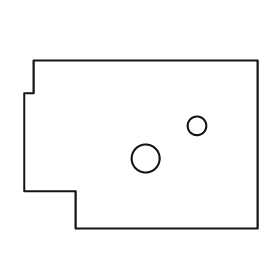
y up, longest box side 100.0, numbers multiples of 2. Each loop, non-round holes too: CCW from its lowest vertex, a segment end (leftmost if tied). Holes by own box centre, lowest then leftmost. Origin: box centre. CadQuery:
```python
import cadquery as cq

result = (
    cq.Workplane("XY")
    .moveTo(-28.0, -36.0)
    .lineTo(50.0, -36.0)
    .lineTo(50.0, 36.0)
    .lineTo(-46.0, 36.0)
    .lineTo(-46.0, 22.0)
    .lineTo(-50.0, 22.0)
    .lineTo(-50.0, -20.0)
    .lineTo(-28.0, -20.0)
    .close()
    .moveTo(2.0, -6.0)
    .circle(6.0)
    .moveTo(24.0, 8.0)
    .circle(4.0)
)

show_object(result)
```